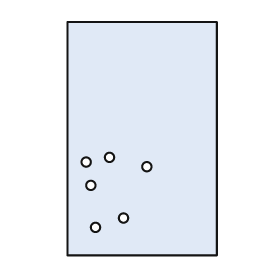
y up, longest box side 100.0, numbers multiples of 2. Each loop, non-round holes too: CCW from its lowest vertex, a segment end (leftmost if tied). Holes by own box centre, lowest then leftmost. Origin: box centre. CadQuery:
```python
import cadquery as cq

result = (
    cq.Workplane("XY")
    .moveTo(-32.0, -50.0)
    .lineTo(32.0, -50.0)
    .lineTo(32.0, 50.0)
    .lineTo(-32.0, 50.0)
    .close()
    .moveTo(-20.0, -38.0)
    .circle(2.0)
    .moveTo(-8.0, -34.0)
    .circle(2.0)
    .moveTo(-22.0, -20.0)
    .circle(2.0)
    .moveTo(2.0, -12.0)
    .circle(2.0)
    .moveTo(-24.0, -10.0)
    .circle(2.0)
    .moveTo(-14.0, -8.0)
    .circle(2.0)
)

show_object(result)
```